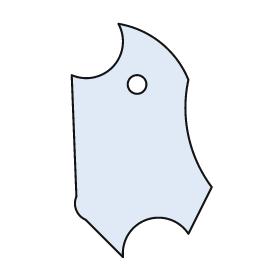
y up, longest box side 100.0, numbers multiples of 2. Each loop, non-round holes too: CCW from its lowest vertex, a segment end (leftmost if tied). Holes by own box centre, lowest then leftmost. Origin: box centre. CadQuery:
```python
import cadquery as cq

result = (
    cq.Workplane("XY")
    .moveTo(-8.0, -50.0)
    .threePointArc((2.0, -34.0), (20.0, -40.0))
    .lineTo(30.0, -20.0)
    .threePointArc((20.0, 2.0), (20.0, 26.0))
    .threePointArc((8.0, 42.0), (-10.0, 50.0))
    .threePointArc((-12.0, 32.0), (-30.0, 28.0))
    .lineTo(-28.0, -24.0)
    .threePointArc((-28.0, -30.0), (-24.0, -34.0))
    .close()
    .moveTo(-2.0, 24.0)
    .circle(4.0)
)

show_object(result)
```